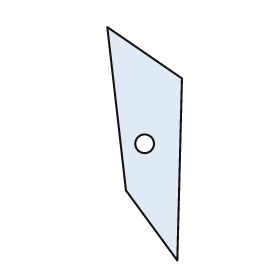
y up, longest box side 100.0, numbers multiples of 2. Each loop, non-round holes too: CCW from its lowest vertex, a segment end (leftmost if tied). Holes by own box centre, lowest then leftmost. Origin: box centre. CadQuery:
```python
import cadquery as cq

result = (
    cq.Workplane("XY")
    .moveTo(14.0, -50.0)
    .lineTo(16.0, 28.0)
    .lineTo(-16.0, 50.0)
    .lineTo(-8.0, -20.0)
    .close()
    .moveTo(0.0, 0.0)
    .circle(4.0)
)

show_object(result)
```